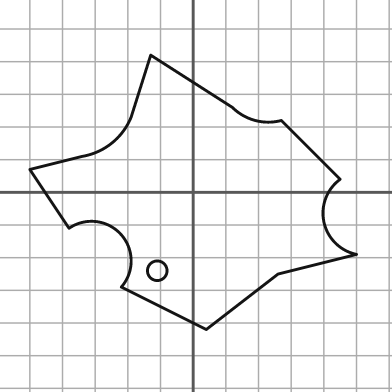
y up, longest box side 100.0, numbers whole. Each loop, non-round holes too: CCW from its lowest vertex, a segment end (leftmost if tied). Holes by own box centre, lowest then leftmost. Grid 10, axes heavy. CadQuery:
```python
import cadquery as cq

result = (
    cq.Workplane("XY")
    .moveTo(4.0, -42.0)
    .lineTo(26.0, -25.0)
    .lineTo(50.0, -19.0)
    .threePointArc((40.0, -9.0), (45.0, 4.0))
    .lineTo(27.0, 22.0)
    .threePointArc((19.0, 22.0), (12.0, 26.0))
    .lineTo(-13.0, 42.0)
    .lineTo(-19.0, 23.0)
    .threePointArc((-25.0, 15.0), (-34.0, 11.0))
    .lineTo(-50.0, 7.0)
    .lineTo(-38.0, -11.0)
    .threePointArc((-22.0, -13.0), (-22.0, -29.0))
    .close()
    .moveTo(-11.0, -24.0)
    .circle(3.0)
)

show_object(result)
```